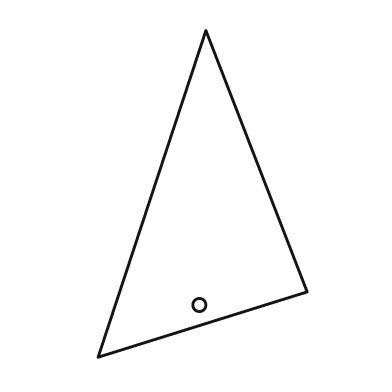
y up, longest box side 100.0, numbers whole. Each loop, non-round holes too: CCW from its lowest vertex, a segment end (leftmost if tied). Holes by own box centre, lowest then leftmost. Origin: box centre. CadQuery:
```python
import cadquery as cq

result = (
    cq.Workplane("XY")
    .moveTo(-32.0, -50.0)
    .lineTo(32.0, -30.0)
    .lineTo(1.0, 50.0)
    .close()
    .moveTo(-1.0, -34.0)
    .circle(2.0)
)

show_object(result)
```